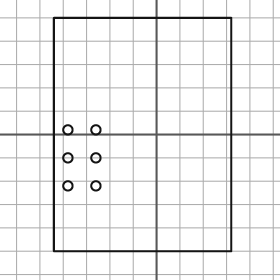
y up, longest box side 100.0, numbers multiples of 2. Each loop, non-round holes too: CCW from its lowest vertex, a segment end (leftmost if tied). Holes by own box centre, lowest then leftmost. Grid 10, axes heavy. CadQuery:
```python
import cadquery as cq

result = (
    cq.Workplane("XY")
    .moveTo(-44.0, -50.0)
    .lineTo(32.0, -50.0)
    .lineTo(32.0, 50.0)
    .lineTo(-44.0, 50.0)
    .close()
    .moveTo(-38.0, -22.0)
    .circle(2.0)
    .moveTo(-26.0, -22.0)
    .circle(2.0)
    .moveTo(-38.0, -10.0)
    .circle(2.0)
    .moveTo(-26.0, -10.0)
    .circle(2.0)
    .moveTo(-38.0, 2.0)
    .circle(2.0)
    .moveTo(-26.0, 2.0)
    .circle(2.0)
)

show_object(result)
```